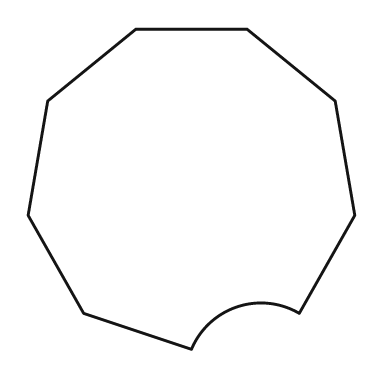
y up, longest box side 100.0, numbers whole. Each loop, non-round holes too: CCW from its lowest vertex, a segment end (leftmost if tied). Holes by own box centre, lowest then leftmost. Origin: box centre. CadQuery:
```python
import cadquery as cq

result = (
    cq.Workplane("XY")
    .moveTo(0.0, -49.0)
    .threePointArc((14.0, -36.0), (33.0, -38.0))
    .lineTo(50.0, -8.0)
    .lineTo(44.0, 27.0)
    .lineTo(17.0, 49.0)
    .lineTo(-17.0, 49.0)
    .lineTo(-44.0, 27.0)
    .lineTo(-50.0, -8.0)
    .lineTo(-33.0, -38.0)
    .close()
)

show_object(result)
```